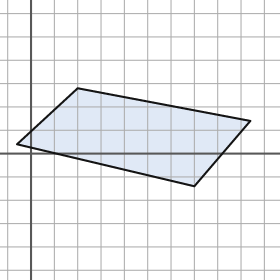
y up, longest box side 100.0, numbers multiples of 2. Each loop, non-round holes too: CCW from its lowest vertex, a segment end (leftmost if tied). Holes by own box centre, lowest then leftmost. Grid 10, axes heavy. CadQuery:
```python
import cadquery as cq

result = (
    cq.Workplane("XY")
    .moveTo(70.0, -14.0)
    .lineTo(94.0, 14.0)
    .lineTo(20.0, 28.0)
    .lineTo(-6.0, 4.0)
    .close()
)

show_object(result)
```